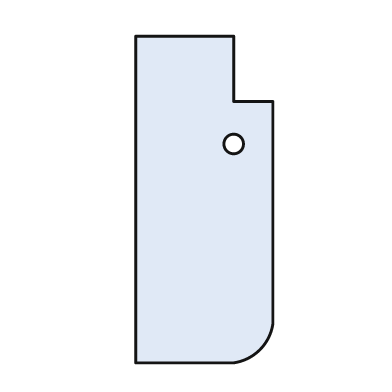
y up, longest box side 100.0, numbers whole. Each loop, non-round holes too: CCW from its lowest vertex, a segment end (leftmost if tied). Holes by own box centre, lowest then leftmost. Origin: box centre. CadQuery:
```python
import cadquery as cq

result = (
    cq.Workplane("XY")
    .moveTo(-21.0, -50.0)
    .lineTo(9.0, -50.0)
    .threePointArc((17.0, -46.0), (21.0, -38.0))
    .lineTo(21.0, 30.0)
    .lineTo(9.0, 30.0)
    .lineTo(9.0, 50.0)
    .lineTo(-21.0, 50.0)
    .close()
    .moveTo(9.0, 17.0)
    .circle(3.0)
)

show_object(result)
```